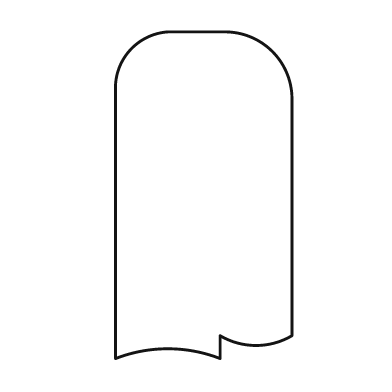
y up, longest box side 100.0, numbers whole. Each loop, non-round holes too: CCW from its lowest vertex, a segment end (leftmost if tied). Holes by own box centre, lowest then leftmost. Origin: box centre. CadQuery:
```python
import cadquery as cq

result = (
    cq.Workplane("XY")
    .moveTo(-27.0, -50.0)
    .threePointArc((-11.0, -47.0), (5.0, -50.0))
    .lineTo(5.0, -43.0)
    .threePointArc((16.0, -46.0), (27.0, -43.0))
    .lineTo(27.0, 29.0)
    .threePointArc((21.0, 44.0), (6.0, 50.0))
    .lineTo(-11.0, 50.0)
    .threePointArc((-22.0, 45.0), (-27.0, 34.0))
    .close()
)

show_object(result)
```